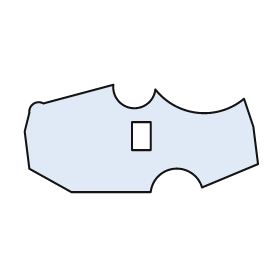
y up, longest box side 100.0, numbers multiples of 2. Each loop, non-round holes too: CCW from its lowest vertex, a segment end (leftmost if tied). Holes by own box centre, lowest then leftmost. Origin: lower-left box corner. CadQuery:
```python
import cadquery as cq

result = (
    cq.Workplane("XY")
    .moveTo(20.0, 0.0)
    .lineTo(54.0, 0.0)
    .threePointArc((64.0, 10.0), (76.0, 2.0))
    .lineTo(100.0, 12.0)
    .lineTo(98.0, 28.0)
    .lineTo(94.0, 40.0)
    .threePointArc((74.0, 34.0), (56.0, 44.0))
    .threePointArc((46.0, 36.0), (38.0, 46.0))
    .lineTo(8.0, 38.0)
    .threePointArc((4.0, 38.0), (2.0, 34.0))
    .lineTo(0.0, 26.0)
    .lineTo(2.0, 10.0)
    .close()
    .moveTo(46.0, 18.0)
    .lineTo(54.0, 18.0)
    .lineTo(54.0, 30.0)
    .lineTo(46.0, 30.0)
    .close()
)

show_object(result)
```